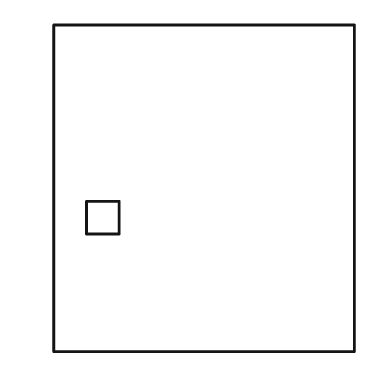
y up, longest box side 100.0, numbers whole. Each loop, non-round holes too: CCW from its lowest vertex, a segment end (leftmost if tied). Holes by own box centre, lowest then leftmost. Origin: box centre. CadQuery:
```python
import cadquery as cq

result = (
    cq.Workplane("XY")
    .moveTo(-46.0, -50.0)
    .lineTo(46.0, -50.0)
    .lineTo(46.0, 50.0)
    .lineTo(-46.0, 50.0)
    .close()
    .moveTo(-36.0, -14.0)
    .lineTo(-26.0, -14.0)
    .lineTo(-26.0, -4.0)
    .lineTo(-36.0, -4.0)
    .close()
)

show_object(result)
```